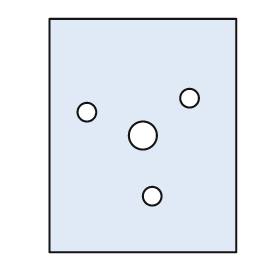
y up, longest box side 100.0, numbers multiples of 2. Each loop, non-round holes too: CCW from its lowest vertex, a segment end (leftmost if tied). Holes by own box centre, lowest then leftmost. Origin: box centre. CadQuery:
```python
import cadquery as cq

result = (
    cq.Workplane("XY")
    .moveTo(-40.0, -50.0)
    .lineTo(40.0, -50.0)
    .lineTo(40.0, 50.0)
    .lineTo(-40.0, 50.0)
    .close()
    .moveTo(4.0, -26.0)
    .circle(4.0)
    .moveTo(0.0, 0.0)
    .circle(6.0)
    .moveTo(-24.0, 10.0)
    .circle(4.0)
    .moveTo(20.0, 16.0)
    .circle(4.0)
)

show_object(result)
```